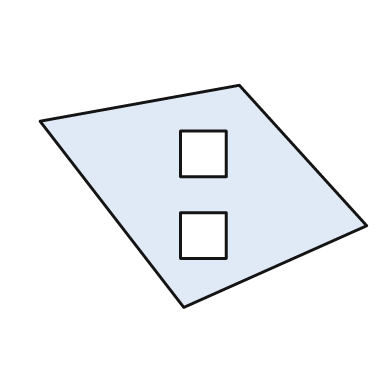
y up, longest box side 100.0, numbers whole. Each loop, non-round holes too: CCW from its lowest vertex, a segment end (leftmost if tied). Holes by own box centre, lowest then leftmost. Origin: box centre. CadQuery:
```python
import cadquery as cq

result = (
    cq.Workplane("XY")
    .moveTo(-6.0, -34.0)
    .lineTo(50.0, -9.0)
    .lineTo(11.0, 34.0)
    .lineTo(-50.0, 23.0)
    .close()
    .moveTo(-7.0, -19.0)
    .lineTo(7.0, -19.0)
    .lineTo(7.0, -5.0)
    .lineTo(-7.0, -5.0)
    .close()
    .moveTo(-7.0, 6.0)
    .lineTo(7.0, 6.0)
    .lineTo(7.0, 20.0)
    .lineTo(-7.0, 20.0)
    .close()
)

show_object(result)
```